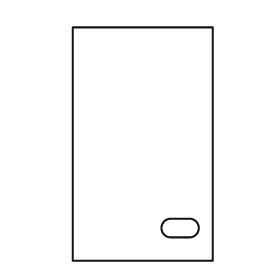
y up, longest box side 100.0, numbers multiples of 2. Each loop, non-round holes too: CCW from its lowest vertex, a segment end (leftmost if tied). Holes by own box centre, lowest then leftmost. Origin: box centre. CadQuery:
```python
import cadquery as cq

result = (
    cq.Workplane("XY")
    .moveTo(-30.0, -50.0)
    .lineTo(30.0, -50.0)
    .lineTo(30.0, 50.0)
    .lineTo(-30.0, 50.0)
    .close()
    .moveTo(12.0, -40.0)
    .lineTo(20.0, -40.0)
    .threePointArc((24.0, -36.0), (20.0, -32.0))
    .lineTo(12.0, -32.0)
    .threePointArc((8.0, -36.0), (12.0, -40.0))
    .close()
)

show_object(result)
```